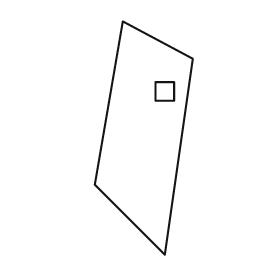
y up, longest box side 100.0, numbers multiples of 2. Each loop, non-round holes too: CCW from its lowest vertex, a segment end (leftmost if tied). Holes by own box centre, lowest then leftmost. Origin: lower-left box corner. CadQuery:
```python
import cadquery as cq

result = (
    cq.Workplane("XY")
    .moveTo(30.0, 0.0)
    .lineTo(42.0, 84.0)
    .lineTo(12.0, 100.0)
    .lineTo(0.0, 30.0)
    .close()
    .moveTo(26.0, 66.0)
    .lineTo(34.0, 66.0)
    .lineTo(34.0, 74.0)
    .lineTo(26.0, 74.0)
    .close()
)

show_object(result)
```